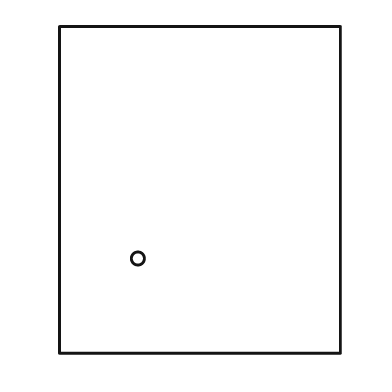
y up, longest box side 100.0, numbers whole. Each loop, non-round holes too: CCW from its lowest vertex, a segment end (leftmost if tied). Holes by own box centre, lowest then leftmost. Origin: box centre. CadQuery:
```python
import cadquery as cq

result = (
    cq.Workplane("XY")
    .moveTo(-43.0, -50.0)
    .lineTo(43.0, -50.0)
    .lineTo(43.0, 50.0)
    .lineTo(-43.0, 50.0)
    .close()
    .moveTo(-19.0, -21.0)
    .circle(2.0)
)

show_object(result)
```